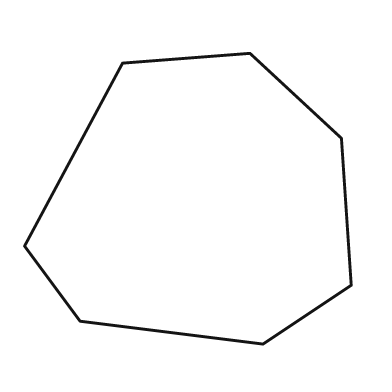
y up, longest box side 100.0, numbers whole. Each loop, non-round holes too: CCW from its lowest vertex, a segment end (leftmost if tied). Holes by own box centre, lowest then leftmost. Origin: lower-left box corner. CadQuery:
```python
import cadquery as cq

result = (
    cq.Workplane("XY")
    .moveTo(73.0, 0.0)
    .lineTo(100.0, 18.0)
    .lineTo(97.0, 63.0)
    .lineTo(69.0, 89.0)
    .lineTo(30.0, 86.0)
    .lineTo(0.0, 30.0)
    .lineTo(17.0, 7.0)
    .close()
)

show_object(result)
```